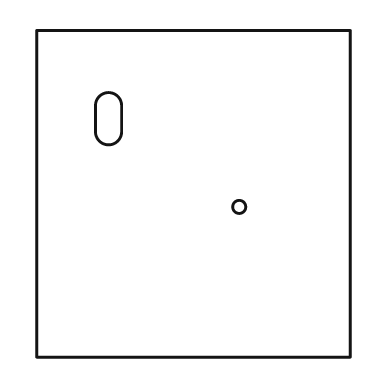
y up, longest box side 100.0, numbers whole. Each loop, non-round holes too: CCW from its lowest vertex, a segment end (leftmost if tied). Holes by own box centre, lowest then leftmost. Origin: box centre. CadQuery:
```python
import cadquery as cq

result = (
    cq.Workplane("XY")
    .moveTo(-48.0, -50.0)
    .lineTo(48.0, -50.0)
    .lineTo(48.0, 50.0)
    .lineTo(-48.0, 50.0)
    .close()
    .moveTo(14.0, -4.0)
    .circle(2.0)
    .moveTo(-30.0, 19.0)
    .threePointArc((-26.0, 15.0), (-22.0, 19.0))
    .lineTo(-22.0, 27.0)
    .threePointArc((-26.0, 31.0), (-30.0, 27.0))
    .close()
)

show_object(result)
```